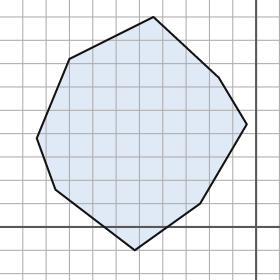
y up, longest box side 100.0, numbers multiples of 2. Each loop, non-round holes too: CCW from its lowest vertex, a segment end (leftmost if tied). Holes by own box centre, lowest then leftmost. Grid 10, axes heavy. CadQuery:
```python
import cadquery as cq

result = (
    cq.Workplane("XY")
    .moveTo(-52.0, -10.0)
    .lineTo(-24.0, 10.0)
    .lineTo(-4.0, 44.0)
    .lineTo(-16.0, 64.0)
    .lineTo(-44.0, 90.0)
    .lineTo(-80.0, 72.0)
    .lineTo(-94.0, 38.0)
    .lineTo(-86.0, 16.0)
    .close()
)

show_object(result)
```